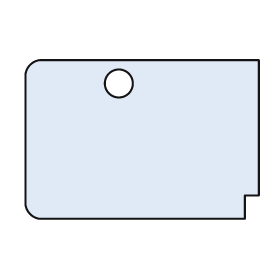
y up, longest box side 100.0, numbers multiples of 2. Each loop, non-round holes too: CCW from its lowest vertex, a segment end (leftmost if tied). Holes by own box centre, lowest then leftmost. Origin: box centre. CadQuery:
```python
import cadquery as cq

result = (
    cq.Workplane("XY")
    .moveTo(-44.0, -34.0)
    .lineTo(44.0, -34.0)
    .lineTo(44.0, -24.0)
    .lineTo(50.0, -24.0)
    .lineTo(50.0, 34.0)
    .lineTo(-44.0, 34.0)
    .threePointArc((-48.0, 32.0), (-50.0, 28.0))
    .lineTo(-50.0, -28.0)
    .threePointArc((-48.0, -32.0), (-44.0, -34.0))
    .close()
    .moveTo(-10.0, 24.0)
    .circle(6.0)
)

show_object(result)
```